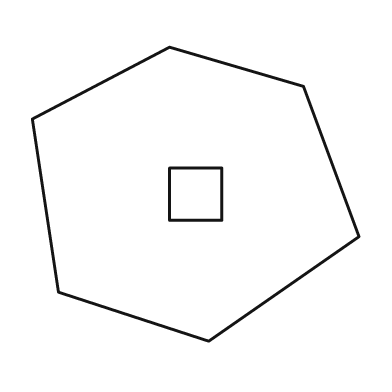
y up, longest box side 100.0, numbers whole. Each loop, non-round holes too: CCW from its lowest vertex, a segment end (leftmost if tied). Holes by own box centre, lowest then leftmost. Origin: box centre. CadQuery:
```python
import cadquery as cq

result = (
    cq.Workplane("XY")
    .moveTo(4.0, -45.0)
    .lineTo(50.0, -13.0)
    .lineTo(33.0, 33.0)
    .lineTo(-8.0, 45.0)
    .lineTo(-50.0, 23.0)
    .lineTo(-42.0, -30.0)
    .close()
    .moveTo(-8.0, -8.0)
    .lineTo(8.0, -8.0)
    .lineTo(8.0, 8.0)
    .lineTo(-8.0, 8.0)
    .close()
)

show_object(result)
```